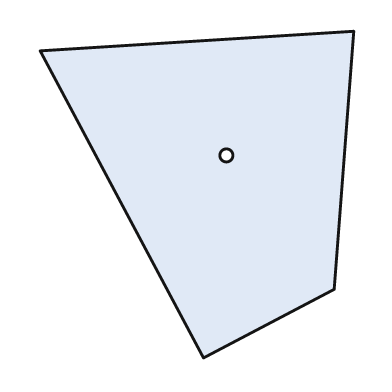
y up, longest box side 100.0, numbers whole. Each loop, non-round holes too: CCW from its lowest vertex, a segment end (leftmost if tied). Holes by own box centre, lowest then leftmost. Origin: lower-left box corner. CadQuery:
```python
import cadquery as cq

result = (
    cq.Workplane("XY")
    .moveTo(50.0, 0.0)
    .lineTo(90.0, 21.0)
    .lineTo(96.0, 100.0)
    .lineTo(0.0, 94.0)
    .close()
    .moveTo(57.0, 62.0)
    .circle(2.0)
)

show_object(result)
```